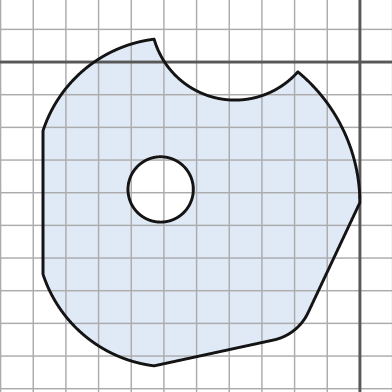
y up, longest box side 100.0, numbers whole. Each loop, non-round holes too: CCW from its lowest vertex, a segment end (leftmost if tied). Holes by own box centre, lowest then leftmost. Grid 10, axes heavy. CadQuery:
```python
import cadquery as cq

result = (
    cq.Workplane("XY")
    .moveTo(-63.0, -93.0)
    .lineTo(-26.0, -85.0)
    .threePointArc((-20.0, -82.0), (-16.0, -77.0))
    .lineTo(0.0, -43.0)
    .threePointArc((-5.0, -21.0), (-19.0, -3.0))
    .threePointArc((-44.0, -11.0), (-63.0, 7.0))
    .threePointArc((-84.0, -2.0), (-97.0, -21.0))
    .lineTo(-97.0, -65.0)
    .threePointArc((-84.0, -84.0), (-63.0, -93.0))
    .close()
    .moveTo(-61.0, -39.0)
    .circle(10.0)
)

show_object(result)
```